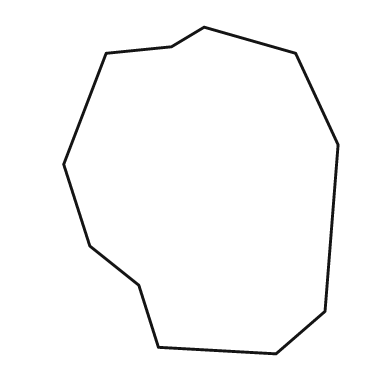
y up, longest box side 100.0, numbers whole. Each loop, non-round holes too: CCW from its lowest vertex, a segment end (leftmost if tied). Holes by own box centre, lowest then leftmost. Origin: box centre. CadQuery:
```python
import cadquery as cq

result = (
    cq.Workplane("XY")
    .moveTo(23.0, -50.0)
    .lineTo(38.0, -37.0)
    .lineTo(42.0, 14.0)
    .lineTo(29.0, 42.0)
    .lineTo(1.0, 50.0)
    .lineTo(-9.0, 44.0)
    .lineTo(-29.0, 42.0)
    .lineTo(-42.0, 8.0)
    .lineTo(-34.0, -17.0)
    .lineTo(-19.0, -29.0)
    .lineTo(-13.0, -48.0)
    .close()
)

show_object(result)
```